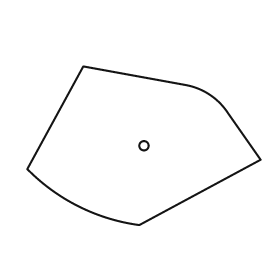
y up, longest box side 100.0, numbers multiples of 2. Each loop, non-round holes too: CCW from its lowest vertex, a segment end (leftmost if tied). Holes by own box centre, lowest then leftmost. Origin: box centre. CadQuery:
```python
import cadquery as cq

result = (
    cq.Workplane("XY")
    .moveTo(-2.0, -34.0)
    .lineTo(50.0, -6.0)
    .lineTo(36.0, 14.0)
    .threePointArc((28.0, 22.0), (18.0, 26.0))
    .lineTo(-26.0, 34.0)
    .lineTo(-50.0, -10.0)
    .threePointArc((-28.0, -26.0), (-2.0, -34.0))
    .close()
    .moveTo(0.0, 0.0)
    .circle(2.0)
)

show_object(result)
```